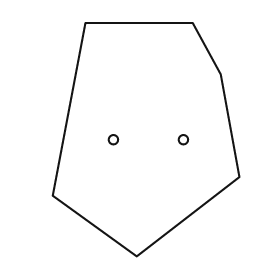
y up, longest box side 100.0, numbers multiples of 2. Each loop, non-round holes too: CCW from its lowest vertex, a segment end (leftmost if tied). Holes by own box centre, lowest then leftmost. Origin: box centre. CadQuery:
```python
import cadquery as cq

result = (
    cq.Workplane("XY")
    .moveTo(-4.0, -50.0)
    .lineTo(40.0, -16.0)
    .lineTo(32.0, 28.0)
    .lineTo(20.0, 50.0)
    .lineTo(-26.0, 50.0)
    .lineTo(-40.0, -24.0)
    .close()
    .moveTo(-14.0, 0.0)
    .circle(2.0)
    .moveTo(16.0, 0.0)
    .circle(2.0)
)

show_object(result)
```